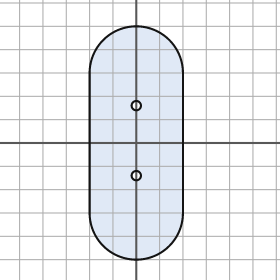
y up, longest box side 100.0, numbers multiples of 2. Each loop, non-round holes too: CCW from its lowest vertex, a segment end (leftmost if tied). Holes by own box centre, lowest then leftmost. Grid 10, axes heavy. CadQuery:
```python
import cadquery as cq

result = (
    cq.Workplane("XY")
    .moveTo(-20.0, -30.0)
    .threePointArc((0.0, -50.0), (20.0, -30.0))
    .lineTo(20.0, 30.0)
    .threePointArc((0.0, 50.0), (-20.0, 30.0))
    .close()
    .moveTo(0.0, -14.0)
    .circle(2.0)
    .moveTo(0.0, 16.0)
    .circle(2.0)
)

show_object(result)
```